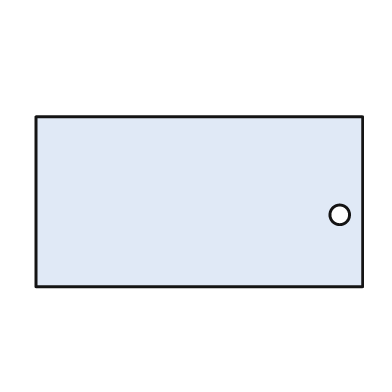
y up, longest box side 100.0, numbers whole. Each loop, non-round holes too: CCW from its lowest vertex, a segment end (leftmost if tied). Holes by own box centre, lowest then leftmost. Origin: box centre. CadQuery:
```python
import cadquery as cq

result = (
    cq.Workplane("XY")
    .moveTo(-50.0, -26.0)
    .lineTo(50.0, -26.0)
    .lineTo(50.0, 26.0)
    .lineTo(-50.0, 26.0)
    .close()
    .moveTo(43.0, -4.0)
    .circle(3.0)
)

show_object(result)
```